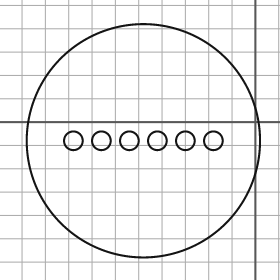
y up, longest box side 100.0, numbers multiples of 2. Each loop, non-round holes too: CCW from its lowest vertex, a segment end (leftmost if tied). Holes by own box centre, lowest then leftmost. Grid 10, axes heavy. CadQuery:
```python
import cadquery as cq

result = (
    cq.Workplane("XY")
    .moveTo(-48.0, -8.0)
    .circle(50.0)
    .moveTo(-78.0, -8.0)
    .circle(4.0)
    .moveTo(-66.0, -8.0)
    .circle(4.0)
    .moveTo(-54.0, -8.0)
    .circle(4.0)
    .moveTo(-42.0, -8.0)
    .circle(4.0)
    .moveTo(-30.0, -8.0)
    .circle(4.0)
    .moveTo(-18.0, -8.0)
    .circle(4.0)
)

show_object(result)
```